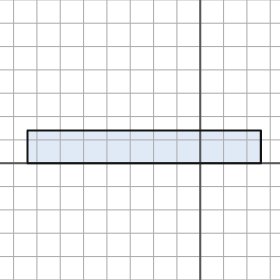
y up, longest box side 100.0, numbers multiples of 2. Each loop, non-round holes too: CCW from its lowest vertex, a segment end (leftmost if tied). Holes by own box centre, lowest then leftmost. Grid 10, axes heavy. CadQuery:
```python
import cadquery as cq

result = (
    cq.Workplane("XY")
    .moveTo(-74.0, 0.0)
    .lineTo(26.0, 0.0)
    .lineTo(26.0, 14.0)
    .lineTo(-74.0, 14.0)
    .close()
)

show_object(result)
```